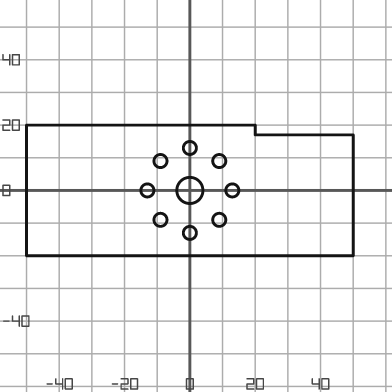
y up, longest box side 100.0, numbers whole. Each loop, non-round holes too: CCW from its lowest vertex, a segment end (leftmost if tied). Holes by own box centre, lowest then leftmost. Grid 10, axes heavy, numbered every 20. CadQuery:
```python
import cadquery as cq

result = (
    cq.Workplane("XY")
    .moveTo(-50.0, -20.0)
    .lineTo(50.0, -20.0)
    .lineTo(50.0, 17.0)
    .lineTo(20.0, 17.0)
    .lineTo(20.0, 20.0)
    .lineTo(-50.0, 20.0)
    .close()
    .moveTo(0.0, -13.0)
    .circle(2.0)
    .moveTo(-9.0, -9.0)
    .circle(2.0)
    .moveTo(9.0, -9.0)
    .circle(2.0)
    .moveTo(-13.0, 0.0)
    .circle(2.0)
    .moveTo(0.0, 0.0)
    .circle(4.0)
    .moveTo(13.0, 0.0)
    .circle(2.0)
    .moveTo(-9.0, 9.0)
    .circle(2.0)
    .moveTo(9.0, 9.0)
    .circle(2.0)
    .moveTo(0.0, 13.0)
    .circle(2.0)
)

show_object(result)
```